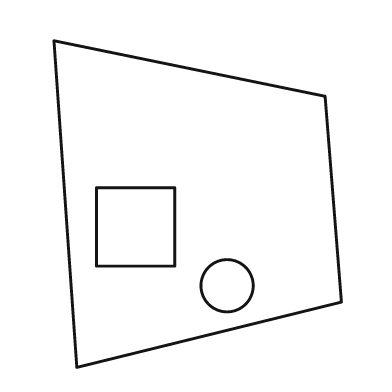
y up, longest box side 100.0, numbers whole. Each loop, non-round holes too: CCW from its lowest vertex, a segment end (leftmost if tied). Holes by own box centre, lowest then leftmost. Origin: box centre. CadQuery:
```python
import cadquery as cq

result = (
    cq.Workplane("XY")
    .moveTo(-37.0, -50.0)
    .lineTo(44.0, -30.0)
    .lineTo(39.0, 33.0)
    .lineTo(-44.0, 50.0)
    .close()
    .moveTo(9.0, -25.0)
    .circle(8.0)
    .moveTo(-31.0, -19.0)
    .lineTo(-7.0, -19.0)
    .lineTo(-7.0, 5.0)
    .lineTo(-31.0, 5.0)
    .close()
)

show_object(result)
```